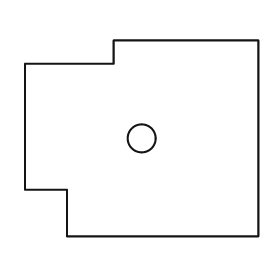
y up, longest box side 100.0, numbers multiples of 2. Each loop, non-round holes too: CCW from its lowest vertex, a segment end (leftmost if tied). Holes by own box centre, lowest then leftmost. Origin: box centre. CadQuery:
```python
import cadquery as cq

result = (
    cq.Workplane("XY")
    .moveTo(-32.0, -42.0)
    .lineTo(50.0, -42.0)
    .lineTo(50.0, 42.0)
    .lineTo(-12.0, 42.0)
    .lineTo(-12.0, 32.0)
    .lineTo(-50.0, 32.0)
    .lineTo(-50.0, -22.0)
    .lineTo(-32.0, -22.0)
    .close()
    .moveTo(0.0, 0.0)
    .circle(6.0)
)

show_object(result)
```